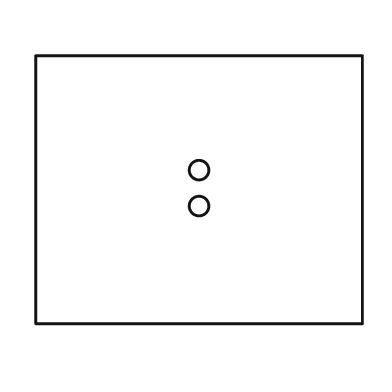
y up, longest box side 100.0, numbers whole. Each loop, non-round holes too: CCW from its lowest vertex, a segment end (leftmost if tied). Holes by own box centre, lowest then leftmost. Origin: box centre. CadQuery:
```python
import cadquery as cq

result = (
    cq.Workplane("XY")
    .moveTo(-50.0, -41.0)
    .lineTo(50.0, -41.0)
    .lineTo(50.0, 41.0)
    .lineTo(-50.0, 41.0)
    .close()
    .moveTo(0.0, -5.0)
    .circle(3.0)
    .moveTo(0.0, 6.0)
    .circle(3.0)
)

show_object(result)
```